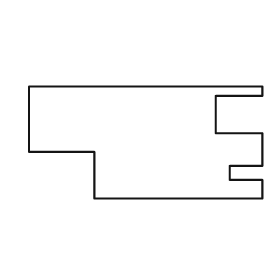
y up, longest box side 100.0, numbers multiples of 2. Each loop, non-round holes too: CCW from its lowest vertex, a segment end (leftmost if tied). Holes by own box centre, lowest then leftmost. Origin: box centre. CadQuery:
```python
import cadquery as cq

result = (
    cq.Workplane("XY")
    .moveTo(-22.0, -24.0)
    .lineTo(50.0, -24.0)
    .lineTo(50.0, -16.0)
    .lineTo(36.0, -16.0)
    .lineTo(36.0, -10.0)
    .lineTo(50.0, -10.0)
    .lineTo(50.0, 4.0)
    .lineTo(30.0, 4.0)
    .lineTo(30.0, 20.0)
    .lineTo(50.0, 20.0)
    .lineTo(50.0, 24.0)
    .lineTo(-50.0, 24.0)
    .lineTo(-50.0, -4.0)
    .lineTo(-22.0, -4.0)
    .close()
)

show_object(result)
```